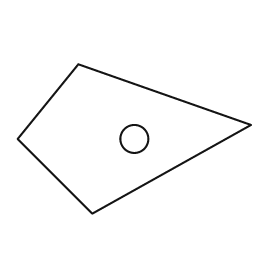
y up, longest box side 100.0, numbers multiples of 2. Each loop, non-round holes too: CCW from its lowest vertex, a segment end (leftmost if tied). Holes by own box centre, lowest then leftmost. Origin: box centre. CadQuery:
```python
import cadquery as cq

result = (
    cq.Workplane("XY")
    .moveTo(-18.0, -32.0)
    .lineTo(50.0, 6.0)
    .lineTo(-24.0, 32.0)
    .lineTo(-50.0, 0.0)
    .close()
    .moveTo(0.0, 0.0)
    .circle(6.0)
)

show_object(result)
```